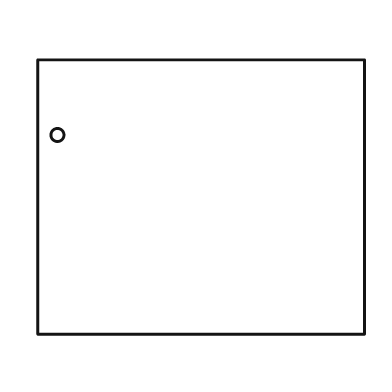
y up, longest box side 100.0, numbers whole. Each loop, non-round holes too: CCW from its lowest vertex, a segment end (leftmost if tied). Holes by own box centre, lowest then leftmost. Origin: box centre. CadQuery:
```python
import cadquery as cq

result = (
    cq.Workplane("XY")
    .moveTo(-50.0, -42.0)
    .lineTo(50.0, -42.0)
    .lineTo(50.0, 42.0)
    .lineTo(-50.0, 42.0)
    .close()
    .moveTo(-44.0, 19.0)
    .circle(2.0)
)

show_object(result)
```